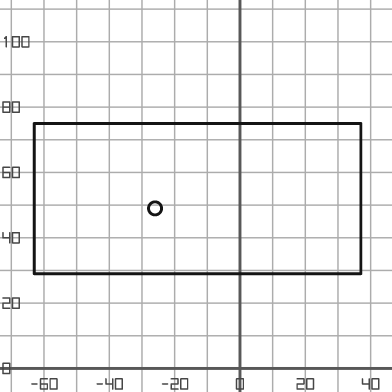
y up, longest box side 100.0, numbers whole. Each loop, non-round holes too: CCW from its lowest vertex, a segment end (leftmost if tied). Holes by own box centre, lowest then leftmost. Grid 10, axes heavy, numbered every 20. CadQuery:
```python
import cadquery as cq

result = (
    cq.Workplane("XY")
    .moveTo(-63.0, 29.0)
    .lineTo(37.0, 29.0)
    .lineTo(37.0, 75.0)
    .lineTo(-63.0, 75.0)
    .close()
    .moveTo(-26.0, 49.0)
    .circle(2.0)
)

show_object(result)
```